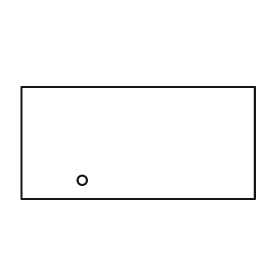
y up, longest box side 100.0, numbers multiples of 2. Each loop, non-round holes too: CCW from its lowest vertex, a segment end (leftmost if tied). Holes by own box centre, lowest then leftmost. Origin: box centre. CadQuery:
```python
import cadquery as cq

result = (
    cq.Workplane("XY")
    .moveTo(-50.0, -24.0)
    .lineTo(50.0, -24.0)
    .lineTo(50.0, 24.0)
    .lineTo(-50.0, 24.0)
    .close()
    .moveTo(-24.0, -16.0)
    .circle(2.0)
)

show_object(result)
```